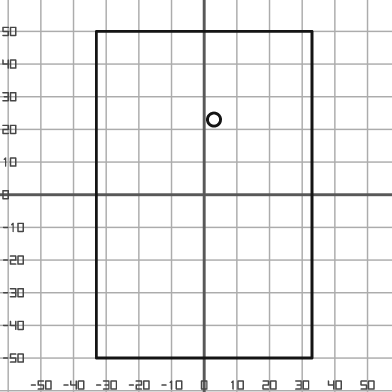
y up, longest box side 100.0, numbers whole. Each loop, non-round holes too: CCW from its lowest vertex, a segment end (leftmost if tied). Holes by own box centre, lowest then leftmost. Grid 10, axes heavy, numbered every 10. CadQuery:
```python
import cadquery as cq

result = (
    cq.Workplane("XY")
    .moveTo(-33.0, -50.0)
    .lineTo(33.0, -50.0)
    .lineTo(33.0, 50.0)
    .lineTo(-33.0, 50.0)
    .close()
    .moveTo(3.0, 23.0)
    .circle(2.0)
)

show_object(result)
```